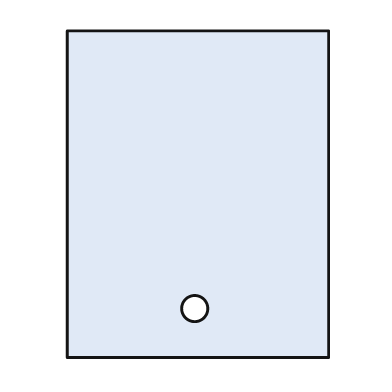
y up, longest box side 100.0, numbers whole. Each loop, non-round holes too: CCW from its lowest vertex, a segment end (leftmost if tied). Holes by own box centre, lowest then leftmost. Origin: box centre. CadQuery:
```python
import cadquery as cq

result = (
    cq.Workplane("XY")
    .moveTo(-40.0, -50.0)
    .lineTo(40.0, -50.0)
    .lineTo(40.0, 50.0)
    .lineTo(-40.0, 50.0)
    .close()
    .moveTo(-1.0, -35.0)
    .circle(4.0)
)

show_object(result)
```